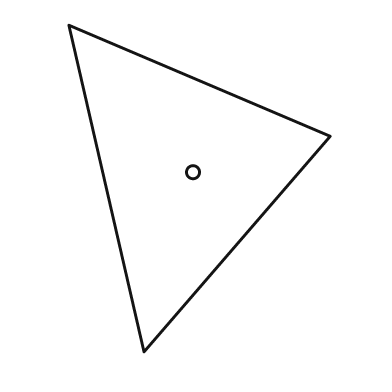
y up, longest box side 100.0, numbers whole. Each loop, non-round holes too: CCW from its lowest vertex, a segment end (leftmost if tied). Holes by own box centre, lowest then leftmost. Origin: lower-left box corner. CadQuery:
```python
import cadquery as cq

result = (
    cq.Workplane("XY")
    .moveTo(23.0, 0.0)
    .lineTo(80.0, 66.0)
    .lineTo(0.0, 100.0)
    .close()
    .moveTo(38.0, 55.0)
    .circle(2.0)
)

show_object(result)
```